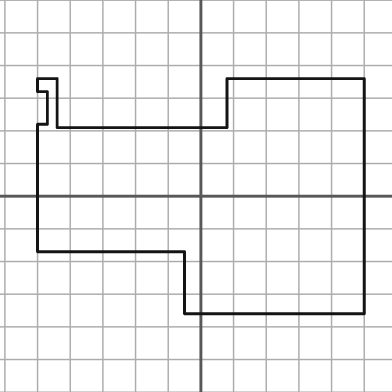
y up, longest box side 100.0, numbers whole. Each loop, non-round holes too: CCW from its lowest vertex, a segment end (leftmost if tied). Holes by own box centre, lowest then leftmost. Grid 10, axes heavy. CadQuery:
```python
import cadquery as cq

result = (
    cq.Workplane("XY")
    .moveTo(-5.0, -36.0)
    .lineTo(50.0, -36.0)
    .lineTo(50.0, 36.0)
    .lineTo(8.0, 36.0)
    .lineTo(8.0, 21.0)
    .lineTo(-44.0, 21.0)
    .lineTo(-44.0, 36.0)
    .lineTo(-50.0, 36.0)
    .lineTo(-50.0, 32.0)
    .lineTo(-47.0, 32.0)
    .lineTo(-47.0, 22.0)
    .lineTo(-50.0, 22.0)
    .lineTo(-50.0, -17.0)
    .lineTo(-5.0, -17.0)
    .close()
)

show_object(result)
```